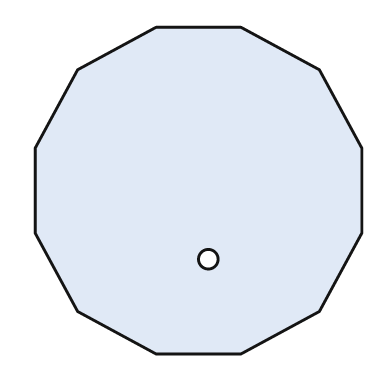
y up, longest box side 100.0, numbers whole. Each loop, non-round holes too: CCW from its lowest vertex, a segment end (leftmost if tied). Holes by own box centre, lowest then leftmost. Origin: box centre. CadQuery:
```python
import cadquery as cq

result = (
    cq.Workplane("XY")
    .moveTo(-13.0, -50.0)
    .lineTo(13.0, -50.0)
    .lineTo(37.0, -37.0)
    .lineTo(50.0, -13.0)
    .lineTo(50.0, 13.0)
    .lineTo(37.0, 37.0)
    .lineTo(13.0, 50.0)
    .lineTo(-13.0, 50.0)
    .lineTo(-37.0, 37.0)
    .lineTo(-50.0, 13.0)
    .lineTo(-50.0, -13.0)
    .lineTo(-37.0, -37.0)
    .close()
    .moveTo(3.0, -21.0)
    .circle(3.0)
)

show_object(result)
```